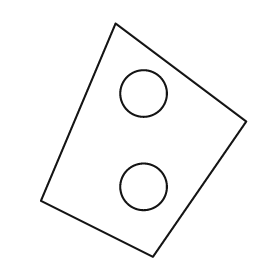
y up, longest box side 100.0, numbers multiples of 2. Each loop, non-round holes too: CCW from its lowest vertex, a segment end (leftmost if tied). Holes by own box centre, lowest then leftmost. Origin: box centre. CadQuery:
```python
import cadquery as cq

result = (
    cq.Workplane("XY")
    .moveTo(4.0, -50.0)
    .lineTo(44.0, 8.0)
    .lineTo(-12.0, 50.0)
    .lineTo(-44.0, -26.0)
    .close()
    .moveTo(0.0, -20.0)
    .circle(10.0)
    .moveTo(0.0, 20.0)
    .circle(10.0)
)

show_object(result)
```